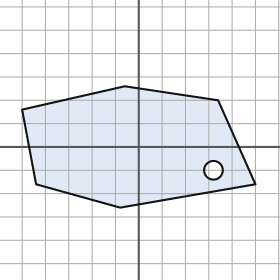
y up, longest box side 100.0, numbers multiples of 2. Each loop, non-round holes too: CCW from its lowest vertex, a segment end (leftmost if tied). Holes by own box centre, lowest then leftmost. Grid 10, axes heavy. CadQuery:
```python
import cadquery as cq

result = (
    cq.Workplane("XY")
    .moveTo(-8.0, -26.0)
    .lineTo(50.0, -16.0)
    .lineTo(34.0, 20.0)
    .lineTo(-6.0, 26.0)
    .lineTo(-50.0, 16.0)
    .lineTo(-44.0, -16.0)
    .close()
    .moveTo(32.0, -10.0)
    .circle(4.0)
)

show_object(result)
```